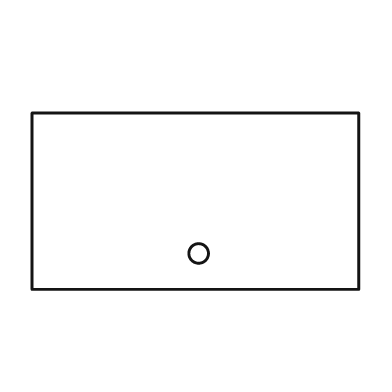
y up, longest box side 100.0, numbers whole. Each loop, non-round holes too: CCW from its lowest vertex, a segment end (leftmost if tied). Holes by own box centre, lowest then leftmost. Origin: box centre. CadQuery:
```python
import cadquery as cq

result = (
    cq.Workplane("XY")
    .moveTo(-50.0, -27.0)
    .lineTo(50.0, -27.0)
    .lineTo(50.0, 27.0)
    .lineTo(-50.0, 27.0)
    .close()
    .moveTo(1.0, -16.0)
    .circle(3.0)
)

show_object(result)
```